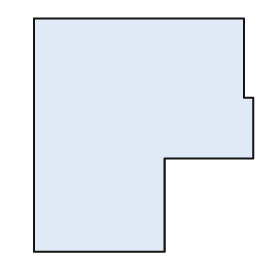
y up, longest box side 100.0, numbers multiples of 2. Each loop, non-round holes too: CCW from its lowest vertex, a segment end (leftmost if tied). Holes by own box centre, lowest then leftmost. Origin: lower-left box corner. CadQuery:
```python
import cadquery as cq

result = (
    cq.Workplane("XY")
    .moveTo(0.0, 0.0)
    .lineTo(56.0, 0.0)
    .lineTo(56.0, 40.0)
    .lineTo(94.0, 40.0)
    .lineTo(94.0, 66.0)
    .lineTo(90.0, 66.0)
    .lineTo(90.0, 100.0)
    .lineTo(0.0, 100.0)
    .close()
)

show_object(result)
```